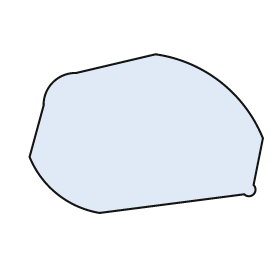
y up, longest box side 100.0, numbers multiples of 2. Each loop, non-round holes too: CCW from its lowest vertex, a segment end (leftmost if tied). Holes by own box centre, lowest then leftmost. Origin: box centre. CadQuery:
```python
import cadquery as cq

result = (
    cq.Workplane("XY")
    .moveTo(-20.0, -34.0)
    .lineTo(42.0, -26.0)
    .threePointArc((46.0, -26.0), (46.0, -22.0))
    .lineTo(50.0, -2.0)
    .threePointArc((32.0, 22.0), (4.0, 34.0))
    .lineTo(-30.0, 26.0)
    .threePointArc((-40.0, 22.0), (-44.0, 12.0))
    .lineTo(-50.0, -10.0)
    .threePointArc((-38.0, -26.0), (-20.0, -34.0))
    .close()
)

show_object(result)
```